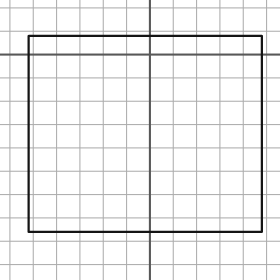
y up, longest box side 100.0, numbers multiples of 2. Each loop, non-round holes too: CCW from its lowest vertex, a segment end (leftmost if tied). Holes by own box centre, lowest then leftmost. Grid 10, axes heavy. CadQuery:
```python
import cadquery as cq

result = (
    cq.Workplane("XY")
    .moveTo(-52.0, -76.0)
    .lineTo(48.0, -76.0)
    .lineTo(48.0, 8.0)
    .lineTo(-52.0, 8.0)
    .close()
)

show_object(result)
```